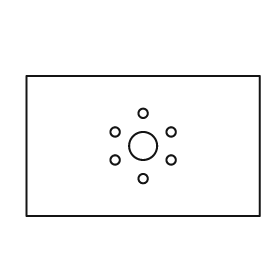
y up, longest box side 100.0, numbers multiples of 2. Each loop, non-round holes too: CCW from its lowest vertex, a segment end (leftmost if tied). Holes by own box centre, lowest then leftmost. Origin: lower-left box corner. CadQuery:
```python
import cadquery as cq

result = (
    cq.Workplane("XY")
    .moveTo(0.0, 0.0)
    .lineTo(100.0, 0.0)
    .lineTo(100.0, 60.0)
    .lineTo(0.0, 60.0)
    .close()
    .moveTo(50.0, 16.0)
    .circle(2.0)
    .moveTo(38.0, 24.0)
    .circle(2.0)
    .moveTo(62.0, 24.0)
    .circle(2.0)
    .moveTo(50.0, 30.0)
    .circle(6.0)
    .moveTo(38.0, 36.0)
    .circle(2.0)
    .moveTo(62.0, 36.0)
    .circle(2.0)
    .moveTo(50.0, 44.0)
    .circle(2.0)
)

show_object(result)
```